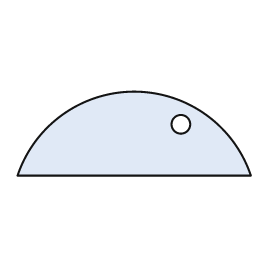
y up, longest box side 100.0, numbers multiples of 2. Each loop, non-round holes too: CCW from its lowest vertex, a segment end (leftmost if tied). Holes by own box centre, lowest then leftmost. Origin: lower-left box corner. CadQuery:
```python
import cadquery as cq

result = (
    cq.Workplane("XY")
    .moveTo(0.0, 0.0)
    .lineTo(100.0, 0.0)
    .threePointArc((50.0, 36.0), (0.0, 0.0))
    .close()
    .moveTo(70.0, 22.0)
    .circle(4.0)
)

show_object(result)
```